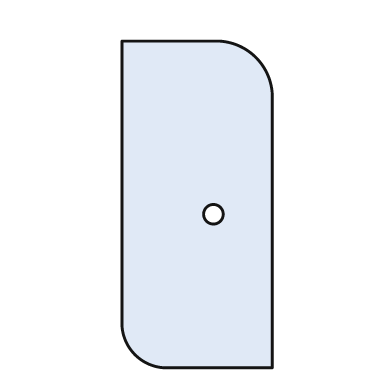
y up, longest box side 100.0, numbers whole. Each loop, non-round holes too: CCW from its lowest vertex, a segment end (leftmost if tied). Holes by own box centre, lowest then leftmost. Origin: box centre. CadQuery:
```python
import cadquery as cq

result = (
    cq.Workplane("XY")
    .moveTo(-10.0, -50.0)
    .lineTo(23.0, -50.0)
    .lineTo(23.0, 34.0)
    .threePointArc((18.0, 45.0), (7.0, 50.0))
    .lineTo(-23.0, 50.0)
    .lineTo(-23.0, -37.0)
    .threePointArc((-19.0, -46.0), (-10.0, -50.0))
    .close()
    .moveTo(5.0, -3.0)
    .circle(3.0)
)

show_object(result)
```